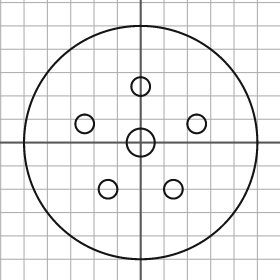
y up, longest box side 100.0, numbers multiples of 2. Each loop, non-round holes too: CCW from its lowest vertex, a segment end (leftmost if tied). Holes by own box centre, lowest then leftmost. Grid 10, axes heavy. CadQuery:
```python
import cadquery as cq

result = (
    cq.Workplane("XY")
    .moveTo(0.0, 0.0)
    .circle(50.0)
    .moveTo(-14.0, -20.0)
    .circle(4.0)
    .moveTo(14.0, -20.0)
    .circle(4.0)
    .moveTo(0.0, 0.0)
    .circle(6.0)
    .moveTo(-24.0, 8.0)
    .circle(4.0)
    .moveTo(24.0, 8.0)
    .circle(4.0)
    .moveTo(0.0, 24.0)
    .circle(4.0)
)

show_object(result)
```